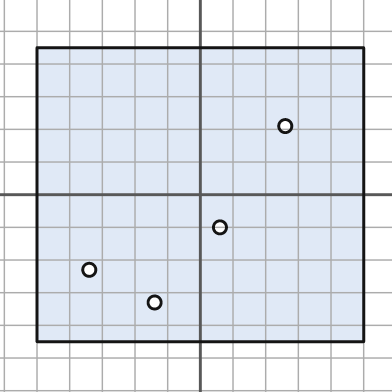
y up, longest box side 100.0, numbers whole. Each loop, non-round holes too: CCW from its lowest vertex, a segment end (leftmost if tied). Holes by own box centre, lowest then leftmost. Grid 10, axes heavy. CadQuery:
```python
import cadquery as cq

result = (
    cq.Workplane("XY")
    .moveTo(-50.0, -45.0)
    .lineTo(50.0, -45.0)
    .lineTo(50.0, 45.0)
    .lineTo(-50.0, 45.0)
    .close()
    .moveTo(-14.0, -33.0)
    .circle(2.0)
    .moveTo(-34.0, -23.0)
    .circle(2.0)
    .moveTo(6.0, -10.0)
    .circle(2.0)
    .moveTo(26.0, 21.0)
    .circle(2.0)
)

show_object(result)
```